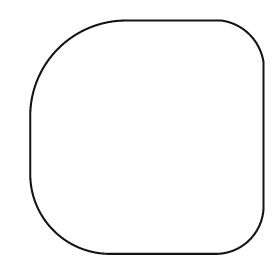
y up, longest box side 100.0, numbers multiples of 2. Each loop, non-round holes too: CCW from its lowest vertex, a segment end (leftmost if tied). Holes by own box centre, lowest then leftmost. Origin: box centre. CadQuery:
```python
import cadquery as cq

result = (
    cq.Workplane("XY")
    .moveTo(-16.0, -50.0)
    .lineTo(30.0, -50.0)
    .threePointArc((44.0, -44.0), (50.0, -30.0))
    .lineTo(50.0, 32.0)
    .threePointArc((44.0, 44.0), (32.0, 50.0))
    .lineTo(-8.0, 50.0)
    .threePointArc((-38.0, 38.0), (-50.0, 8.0))
    .lineTo(-50.0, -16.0)
    .threePointArc((-40.0, -40.0), (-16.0, -50.0))
    .close()
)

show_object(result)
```